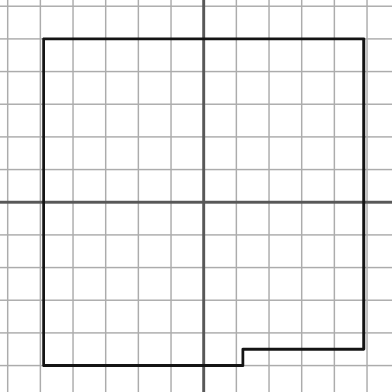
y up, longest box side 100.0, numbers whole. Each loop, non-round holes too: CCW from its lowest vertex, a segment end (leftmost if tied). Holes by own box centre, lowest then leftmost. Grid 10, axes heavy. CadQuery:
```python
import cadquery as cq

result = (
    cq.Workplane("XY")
    .moveTo(-49.0, -50.0)
    .lineTo(12.0, -50.0)
    .lineTo(12.0, -45.0)
    .lineTo(49.0, -45.0)
    .lineTo(49.0, 50.0)
    .lineTo(-49.0, 50.0)
    .close()
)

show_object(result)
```